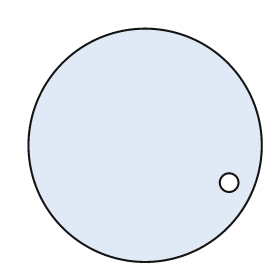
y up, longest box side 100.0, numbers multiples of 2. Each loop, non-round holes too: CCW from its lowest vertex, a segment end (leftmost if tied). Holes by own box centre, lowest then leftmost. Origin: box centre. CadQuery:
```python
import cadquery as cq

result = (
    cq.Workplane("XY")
    .moveTo(0.0, 0.0)
    .circle(50.0)
    .moveTo(36.0, -16.0)
    .circle(4.0)
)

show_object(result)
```